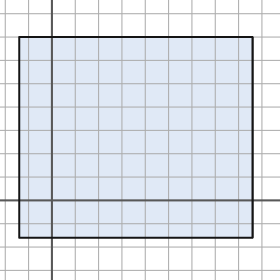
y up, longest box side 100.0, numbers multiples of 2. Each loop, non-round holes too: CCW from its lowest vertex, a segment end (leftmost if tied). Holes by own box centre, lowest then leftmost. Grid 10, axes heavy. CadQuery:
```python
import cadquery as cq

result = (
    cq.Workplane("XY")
    .moveTo(-14.0, -16.0)
    .lineTo(86.0, -16.0)
    .lineTo(86.0, 70.0)
    .lineTo(-14.0, 70.0)
    .close()
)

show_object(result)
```